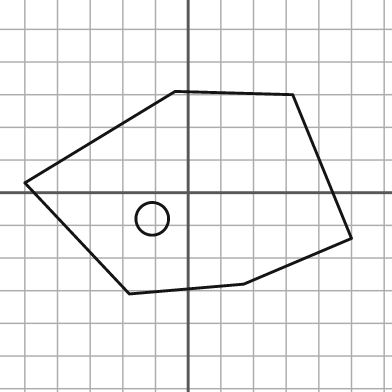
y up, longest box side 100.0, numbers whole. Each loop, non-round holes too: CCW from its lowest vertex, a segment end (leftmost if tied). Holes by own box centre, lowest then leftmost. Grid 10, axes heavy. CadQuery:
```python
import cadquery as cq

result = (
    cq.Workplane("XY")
    .moveTo(-18.0, -31.0)
    .lineTo(17.0, -28.0)
    .lineTo(50.0, -14.0)
    .lineTo(32.0, 30.0)
    .lineTo(-4.0, 31.0)
    .lineTo(-50.0, 3.0)
    .close()
    .moveTo(-11.0, -8.0)
    .circle(5.0)
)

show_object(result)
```